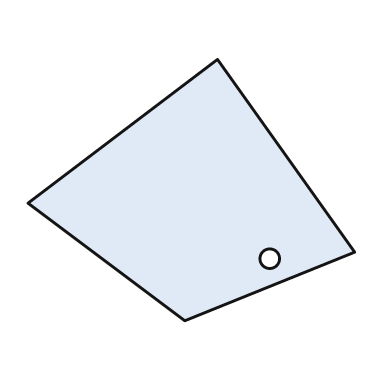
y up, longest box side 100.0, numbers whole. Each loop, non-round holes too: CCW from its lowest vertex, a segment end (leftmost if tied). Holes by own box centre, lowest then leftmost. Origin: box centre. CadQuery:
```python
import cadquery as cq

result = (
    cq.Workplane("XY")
    .moveTo(-2.0, -40.0)
    .lineTo(50.0, -19.0)
    .lineTo(8.0, 40.0)
    .lineTo(-50.0, -4.0)
    .close()
    .moveTo(24.0, -21.0)
    .circle(3.0)
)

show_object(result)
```